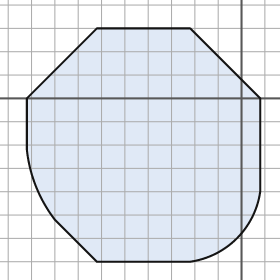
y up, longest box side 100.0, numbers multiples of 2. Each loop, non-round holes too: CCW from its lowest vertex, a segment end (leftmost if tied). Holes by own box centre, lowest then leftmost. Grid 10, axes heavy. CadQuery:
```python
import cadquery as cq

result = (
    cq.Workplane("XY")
    .moveTo(-62.0, -70.0)
    .lineTo(-22.0, -70.0)
    .threePointArc((-2.0, -60.0), (8.0, -40.0))
    .lineTo(8.0, 0.0)
    .lineTo(-22.0, 30.0)
    .lineTo(-62.0, 30.0)
    .lineTo(-92.0, 0.0)
    .lineTo(-92.0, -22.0)
    .threePointArc((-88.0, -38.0), (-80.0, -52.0))
    .close()
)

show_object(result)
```